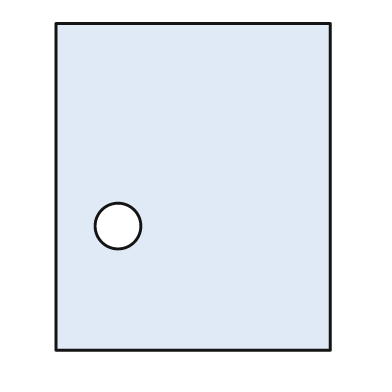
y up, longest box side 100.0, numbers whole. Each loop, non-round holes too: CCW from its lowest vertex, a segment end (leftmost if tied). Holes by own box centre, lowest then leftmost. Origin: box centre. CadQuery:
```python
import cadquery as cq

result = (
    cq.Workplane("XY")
    .moveTo(-42.0, -50.0)
    .lineTo(42.0, -50.0)
    .lineTo(42.0, 50.0)
    .lineTo(-42.0, 50.0)
    .close()
    .moveTo(-23.0, -12.0)
    .circle(7.0)
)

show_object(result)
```